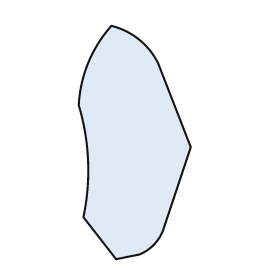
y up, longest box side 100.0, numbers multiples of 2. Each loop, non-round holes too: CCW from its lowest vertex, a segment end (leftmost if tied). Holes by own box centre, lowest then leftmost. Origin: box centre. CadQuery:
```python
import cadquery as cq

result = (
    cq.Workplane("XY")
    .moveTo(-8.0, -50.0)
    .lineTo(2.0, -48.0)
    .threePointArc((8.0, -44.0), (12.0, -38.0))
    .lineTo(24.0, -2.0)
    .lineTo(10.0, 34.0)
    .threePointArc((2.0, 44.0), (-10.0, 50.0))
    .threePointArc((-20.0, 34.0), (-24.0, 16.0))
    .threePointArc((-20.0, -8.0), (-22.0, -32.0))
    .close()
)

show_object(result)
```